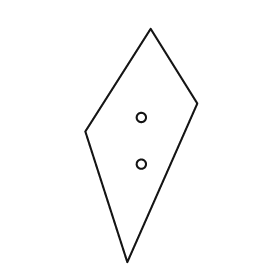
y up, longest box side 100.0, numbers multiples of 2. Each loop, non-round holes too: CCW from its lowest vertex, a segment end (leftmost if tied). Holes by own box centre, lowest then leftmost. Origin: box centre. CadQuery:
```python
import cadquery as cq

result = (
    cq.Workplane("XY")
    .moveTo(-6.0, -50.0)
    .lineTo(24.0, 18.0)
    .lineTo(4.0, 50.0)
    .lineTo(-24.0, 6.0)
    .close()
    .moveTo(0.0, -8.0)
    .circle(2.0)
    .moveTo(0.0, 12.0)
    .circle(2.0)
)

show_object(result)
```